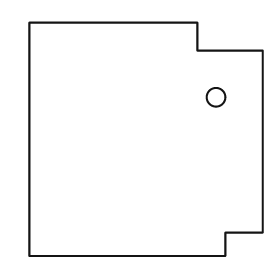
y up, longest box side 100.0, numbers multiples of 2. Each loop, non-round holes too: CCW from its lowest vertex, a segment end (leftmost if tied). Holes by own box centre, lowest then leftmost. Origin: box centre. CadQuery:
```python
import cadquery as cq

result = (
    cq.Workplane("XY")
    .moveTo(-50.0, -50.0)
    .lineTo(34.0, -50.0)
    .lineTo(34.0, -40.0)
    .lineTo(50.0, -40.0)
    .lineTo(50.0, 38.0)
    .lineTo(22.0, 38.0)
    .lineTo(22.0, 50.0)
    .lineTo(-50.0, 50.0)
    .close()
    .moveTo(30.0, 18.0)
    .circle(4.0)
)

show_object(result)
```